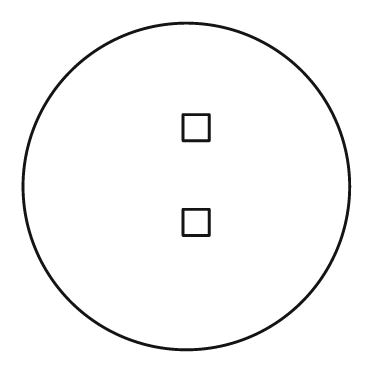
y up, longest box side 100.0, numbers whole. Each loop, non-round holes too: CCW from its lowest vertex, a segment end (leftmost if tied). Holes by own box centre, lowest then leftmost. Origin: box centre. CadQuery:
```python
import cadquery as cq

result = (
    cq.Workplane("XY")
    .moveTo(0.0, 0.0)
    .circle(50.0)
    .moveTo(-1.0, -15.0)
    .lineTo(7.0, -15.0)
    .lineTo(7.0, -7.0)
    .lineTo(-1.0, -7.0)
    .close()
    .moveTo(-1.0, 14.0)
    .lineTo(7.0, 14.0)
    .lineTo(7.0, 22.0)
    .lineTo(-1.0, 22.0)
    .close()
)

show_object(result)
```